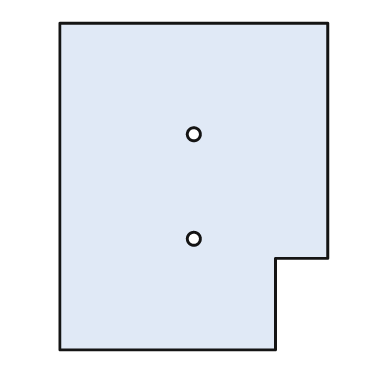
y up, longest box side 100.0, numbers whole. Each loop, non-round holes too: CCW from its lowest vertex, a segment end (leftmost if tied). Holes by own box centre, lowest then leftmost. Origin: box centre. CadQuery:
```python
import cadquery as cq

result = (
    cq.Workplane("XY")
    .moveTo(-41.0, -50.0)
    .lineTo(25.0, -50.0)
    .lineTo(25.0, -22.0)
    .lineTo(41.0, -22.0)
    .lineTo(41.0, 50.0)
    .lineTo(-41.0, 50.0)
    .close()
    .moveTo(0.0, -16.0)
    .circle(2.0)
    .moveTo(0.0, 16.0)
    .circle(2.0)
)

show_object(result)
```